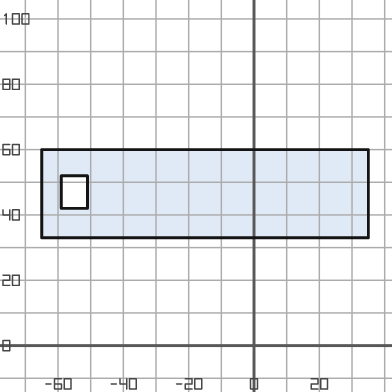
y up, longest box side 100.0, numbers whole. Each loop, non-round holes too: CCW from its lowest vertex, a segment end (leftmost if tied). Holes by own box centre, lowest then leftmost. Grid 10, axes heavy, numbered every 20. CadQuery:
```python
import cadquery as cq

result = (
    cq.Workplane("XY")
    .moveTo(-65.0, 33.0)
    .lineTo(35.0, 33.0)
    .lineTo(35.0, 60.0)
    .lineTo(-65.0, 60.0)
    .close()
    .moveTo(-59.0, 42.0)
    .lineTo(-51.0, 42.0)
    .lineTo(-51.0, 52.0)
    .lineTo(-59.0, 52.0)
    .close()
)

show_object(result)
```